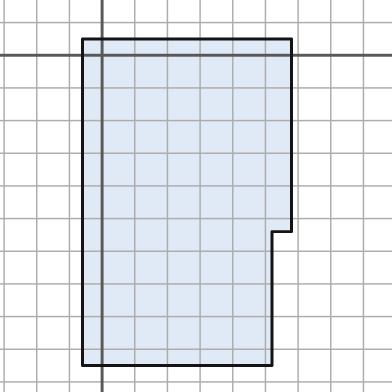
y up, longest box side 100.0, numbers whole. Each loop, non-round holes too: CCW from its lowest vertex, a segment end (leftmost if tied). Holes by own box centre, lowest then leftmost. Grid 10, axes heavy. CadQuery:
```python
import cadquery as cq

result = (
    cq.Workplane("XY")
    .moveTo(-6.0, -95.0)
    .lineTo(52.0, -95.0)
    .lineTo(52.0, -54.0)
    .lineTo(58.0, -54.0)
    .lineTo(58.0, 5.0)
    .lineTo(-6.0, 5.0)
    .close()
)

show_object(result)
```